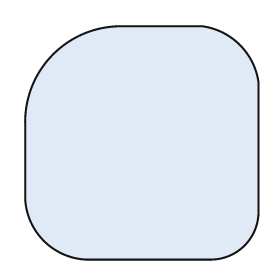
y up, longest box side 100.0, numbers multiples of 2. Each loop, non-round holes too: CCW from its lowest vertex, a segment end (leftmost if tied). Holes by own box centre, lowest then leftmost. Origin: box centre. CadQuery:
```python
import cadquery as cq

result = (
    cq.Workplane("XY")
    .moveTo(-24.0, -50.0)
    .lineTo(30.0, -50.0)
    .threePointArc((44.0, -44.0), (50.0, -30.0))
    .lineTo(50.0, 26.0)
    .threePointArc((42.0, 42.0), (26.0, 50.0))
    .lineTo(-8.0, 50.0)
    .threePointArc((-38.0, 38.0), (-50.0, 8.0))
    .lineTo(-50.0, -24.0)
    .threePointArc((-42.0, -42.0), (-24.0, -50.0))
    .close()
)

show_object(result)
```